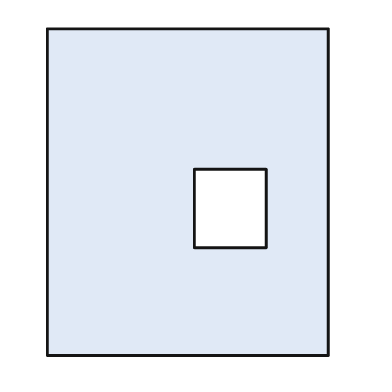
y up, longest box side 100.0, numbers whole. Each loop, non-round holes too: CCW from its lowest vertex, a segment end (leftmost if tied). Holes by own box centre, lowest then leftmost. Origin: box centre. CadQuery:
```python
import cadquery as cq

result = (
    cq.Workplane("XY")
    .moveTo(-43.0, -50.0)
    .lineTo(43.0, -50.0)
    .lineTo(43.0, 50.0)
    .lineTo(-43.0, 50.0)
    .close()
    .moveTo(2.0, -17.0)
    .lineTo(24.0, -17.0)
    .lineTo(24.0, 7.0)
    .lineTo(2.0, 7.0)
    .close()
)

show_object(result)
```